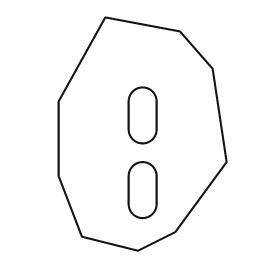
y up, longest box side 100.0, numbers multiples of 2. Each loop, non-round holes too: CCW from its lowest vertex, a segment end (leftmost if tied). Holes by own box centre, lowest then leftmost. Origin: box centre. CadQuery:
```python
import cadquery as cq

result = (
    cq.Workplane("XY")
    .moveTo(-2.0, -50.0)
    .lineTo(14.0, -42.0)
    .lineTo(36.0, -12.0)
    .lineTo(30.0, 28.0)
    .lineTo(16.0, 44.0)
    .lineTo(-16.0, 50.0)
    .lineTo(-36.0, 14.0)
    .lineTo(-36.0, -18.0)
    .lineTo(-26.0, -44.0)
    .close()
    .moveTo(-6.0, -30.0)
    .threePointArc((0.0, -36.0), (6.0, -30.0))
    .lineTo(6.0, -18.0)
    .threePointArc((0.0, -12.0), (-6.0, -18.0))
    .close()
    .moveTo(-6.0, 2.0)
    .threePointArc((0.0, -4.0), (6.0, 2.0))
    .lineTo(6.0, 14.0)
    .threePointArc((0.0, 20.0), (-6.0, 14.0))
    .close()
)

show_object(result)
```